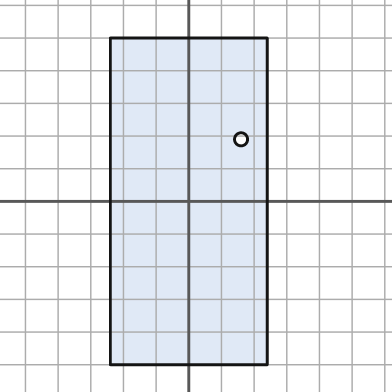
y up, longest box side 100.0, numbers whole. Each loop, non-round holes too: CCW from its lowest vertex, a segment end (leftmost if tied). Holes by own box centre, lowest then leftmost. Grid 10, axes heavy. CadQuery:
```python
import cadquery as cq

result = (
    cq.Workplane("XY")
    .moveTo(-24.0, -50.0)
    .lineTo(24.0, -50.0)
    .lineTo(24.0, 50.0)
    .lineTo(-24.0, 50.0)
    .close()
    .moveTo(16.0, 19.0)
    .circle(2.0)
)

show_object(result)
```